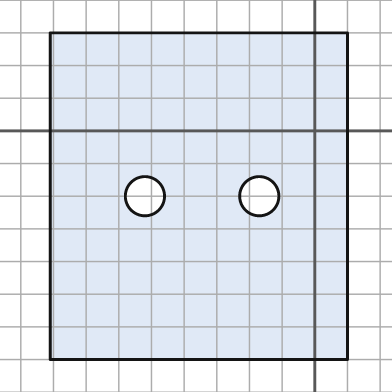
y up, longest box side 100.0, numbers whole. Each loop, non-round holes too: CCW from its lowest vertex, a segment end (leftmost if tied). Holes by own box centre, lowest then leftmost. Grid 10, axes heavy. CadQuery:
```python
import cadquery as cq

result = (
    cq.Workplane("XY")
    .moveTo(-81.0, -70.0)
    .lineTo(10.0, -70.0)
    .lineTo(10.0, 30.0)
    .lineTo(-81.0, 30.0)
    .close()
    .moveTo(-52.0, -20.0)
    .circle(6.0)
    .moveTo(-17.0, -20.0)
    .circle(6.0)
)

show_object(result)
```